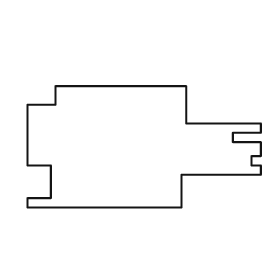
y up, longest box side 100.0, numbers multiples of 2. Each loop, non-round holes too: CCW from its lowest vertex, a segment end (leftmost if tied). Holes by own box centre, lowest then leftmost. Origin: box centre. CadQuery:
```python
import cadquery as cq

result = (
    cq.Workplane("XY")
    .moveTo(-50.0, -26.0)
    .lineTo(16.0, -26.0)
    .lineTo(16.0, -12.0)
    .lineTo(50.0, -12.0)
    .lineTo(50.0, -8.0)
    .lineTo(46.0, -8.0)
    .lineTo(46.0, -4.0)
    .lineTo(50.0, -4.0)
    .lineTo(50.0, 2.0)
    .lineTo(38.0, 2.0)
    .lineTo(38.0, 6.0)
    .lineTo(50.0, 6.0)
    .lineTo(50.0, 10.0)
    .lineTo(18.0, 10.0)
    .lineTo(18.0, 26.0)
    .lineTo(-38.0, 26.0)
    .lineTo(-38.0, 18.0)
    .lineTo(-50.0, 18.0)
    .lineTo(-50.0, -8.0)
    .lineTo(-40.0, -8.0)
    .lineTo(-40.0, -22.0)
    .lineTo(-50.0, -22.0)
    .close()
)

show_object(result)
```